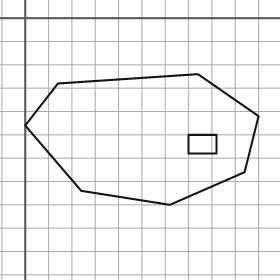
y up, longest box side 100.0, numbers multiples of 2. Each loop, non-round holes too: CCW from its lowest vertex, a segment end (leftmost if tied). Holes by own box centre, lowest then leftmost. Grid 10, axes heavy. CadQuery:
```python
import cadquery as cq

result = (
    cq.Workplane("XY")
    .moveTo(62.0, -80.0)
    .lineTo(94.0, -66.0)
    .lineTo(100.0, -42.0)
    .lineTo(74.0, -24.0)
    .lineTo(14.0, -28.0)
    .lineTo(0.0, -46.0)
    .lineTo(24.0, -74.0)
    .close()
    .moveTo(70.0, -58.0)
    .lineTo(82.0, -58.0)
    .lineTo(82.0, -50.0)
    .lineTo(70.0, -50.0)
    .close()
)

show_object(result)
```